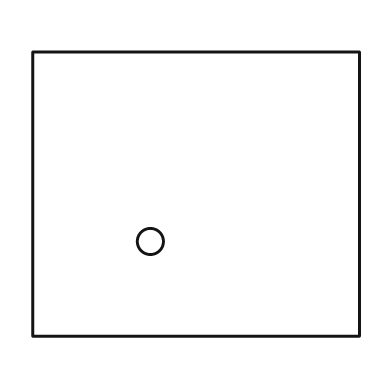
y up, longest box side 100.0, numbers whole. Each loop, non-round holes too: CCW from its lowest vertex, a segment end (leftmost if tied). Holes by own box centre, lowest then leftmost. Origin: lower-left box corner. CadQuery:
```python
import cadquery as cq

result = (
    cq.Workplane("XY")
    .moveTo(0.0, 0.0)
    .lineTo(100.0, 0.0)
    .lineTo(100.0, 87.0)
    .lineTo(0.0, 87.0)
    .close()
    .moveTo(36.0, 29.0)
    .circle(4.0)
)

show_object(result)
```